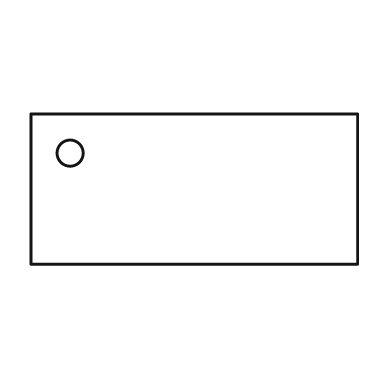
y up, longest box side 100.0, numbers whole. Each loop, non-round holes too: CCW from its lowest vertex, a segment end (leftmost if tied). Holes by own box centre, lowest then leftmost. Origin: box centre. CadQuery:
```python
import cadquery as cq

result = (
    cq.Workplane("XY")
    .moveTo(-50.0, -23.0)
    .lineTo(50.0, -23.0)
    .lineTo(50.0, 23.0)
    .lineTo(-50.0, 23.0)
    .close()
    .moveTo(-38.0, 11.0)
    .circle(4.0)
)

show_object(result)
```